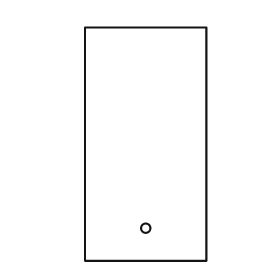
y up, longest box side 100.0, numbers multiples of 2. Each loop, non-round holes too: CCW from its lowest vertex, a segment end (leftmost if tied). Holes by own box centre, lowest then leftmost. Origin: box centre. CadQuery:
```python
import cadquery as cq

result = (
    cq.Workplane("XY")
    .moveTo(-26.0, -50.0)
    .lineTo(26.0, -50.0)
    .lineTo(26.0, 50.0)
    .lineTo(-26.0, 50.0)
    .close()
    .moveTo(0.0, -36.0)
    .circle(2.0)
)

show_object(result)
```